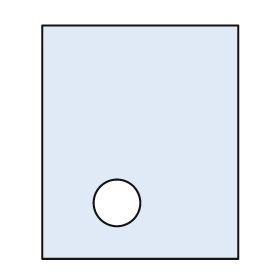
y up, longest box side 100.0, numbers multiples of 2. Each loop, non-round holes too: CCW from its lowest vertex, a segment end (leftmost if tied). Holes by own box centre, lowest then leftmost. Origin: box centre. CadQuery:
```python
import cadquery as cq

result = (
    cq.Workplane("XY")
    .moveTo(-42.0, -50.0)
    .lineTo(42.0, -50.0)
    .lineTo(42.0, 50.0)
    .lineTo(-42.0, 50.0)
    .close()
    .moveTo(-10.0, -26.0)
    .circle(10.0)
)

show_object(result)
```